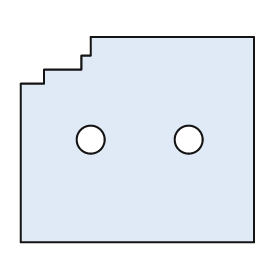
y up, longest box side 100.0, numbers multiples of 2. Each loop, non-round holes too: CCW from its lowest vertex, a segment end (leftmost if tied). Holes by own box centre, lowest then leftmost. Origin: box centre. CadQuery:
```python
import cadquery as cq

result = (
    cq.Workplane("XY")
    .moveTo(-50.0, -44.0)
    .lineTo(50.0, -44.0)
    .lineTo(50.0, 44.0)
    .lineTo(-20.0, 44.0)
    .lineTo(-20.0, 36.0)
    .lineTo(-24.0, 36.0)
    .lineTo(-24.0, 30.0)
    .lineTo(-40.0, 30.0)
    .lineTo(-40.0, 24.0)
    .lineTo(-50.0, 24.0)
    .close()
    .moveTo(-20.0, 0.0)
    .circle(6.0)
    .moveTo(22.0, 0.0)
    .circle(6.0)
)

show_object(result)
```